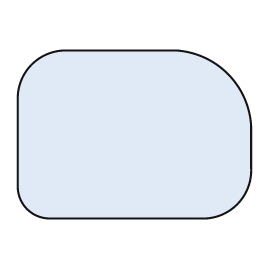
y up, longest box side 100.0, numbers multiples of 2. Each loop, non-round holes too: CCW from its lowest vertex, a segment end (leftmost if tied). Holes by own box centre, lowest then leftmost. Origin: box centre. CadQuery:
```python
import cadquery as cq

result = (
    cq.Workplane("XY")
    .moveTo(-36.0, -36.0)
    .lineTo(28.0, -36.0)
    .threePointArc((44.0, -30.0), (50.0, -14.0))
    .lineTo(50.0, 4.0)
    .threePointArc((40.0, 26.0), (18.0, 36.0))
    .lineTo(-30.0, 36.0)
    .threePointArc((-44.0, 30.0), (-50.0, 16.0))
    .lineTo(-50.0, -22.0)
    .threePointArc((-46.0, -32.0), (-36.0, -36.0))
    .close()
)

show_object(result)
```